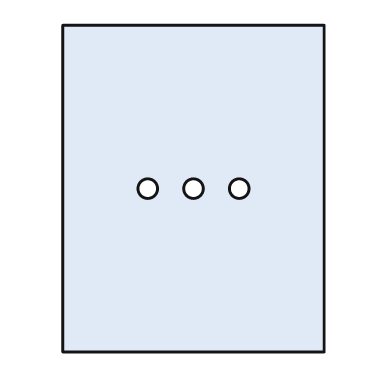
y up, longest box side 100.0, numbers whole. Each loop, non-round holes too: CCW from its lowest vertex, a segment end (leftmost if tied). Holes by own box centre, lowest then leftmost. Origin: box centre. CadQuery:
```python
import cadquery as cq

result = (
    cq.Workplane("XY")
    .moveTo(-40.0, -50.0)
    .lineTo(40.0, -50.0)
    .lineTo(40.0, 50.0)
    .lineTo(-40.0, 50.0)
    .close()
    .moveTo(-14.0, 0.0)
    .circle(3.0)
    .moveTo(0.0, 0.0)
    .circle(3.0)
    .moveTo(14.0, 0.0)
    .circle(3.0)
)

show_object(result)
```